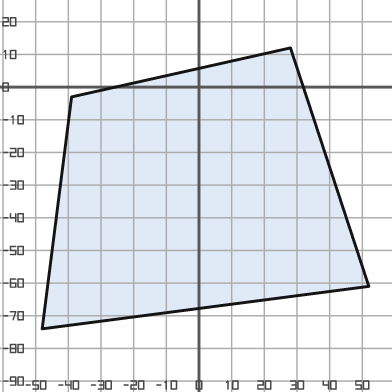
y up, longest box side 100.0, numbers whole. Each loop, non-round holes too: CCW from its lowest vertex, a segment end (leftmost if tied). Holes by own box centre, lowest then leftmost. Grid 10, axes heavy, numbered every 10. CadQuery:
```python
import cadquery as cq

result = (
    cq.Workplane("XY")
    .moveTo(-48.0, -74.0)
    .lineTo(52.0, -61.0)
    .lineTo(28.0, 12.0)
    .lineTo(-39.0, -3.0)
    .close()
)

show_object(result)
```